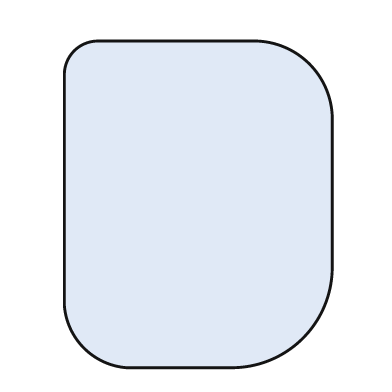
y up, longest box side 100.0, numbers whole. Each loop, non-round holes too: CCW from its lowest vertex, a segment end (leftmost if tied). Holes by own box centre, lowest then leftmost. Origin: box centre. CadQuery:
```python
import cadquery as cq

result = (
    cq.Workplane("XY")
    .moveTo(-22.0, -50.0)
    .lineTo(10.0, -50.0)
    .threePointArc((32.0, -41.0), (41.0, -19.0))
    .lineTo(41.0, 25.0)
    .threePointArc((34.0, 43.0), (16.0, 50.0))
    .lineTo(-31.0, 50.0)
    .threePointArc((-38.0, 47.0), (-41.0, 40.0))
    .lineTo(-41.0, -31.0)
    .threePointArc((-35.0, -44.0), (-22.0, -50.0))
    .close()
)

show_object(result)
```